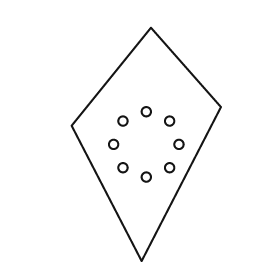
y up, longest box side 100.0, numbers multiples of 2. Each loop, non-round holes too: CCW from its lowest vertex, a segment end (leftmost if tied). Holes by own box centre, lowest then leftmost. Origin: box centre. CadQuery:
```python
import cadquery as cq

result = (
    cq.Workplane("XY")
    .moveTo(-2.0, -50.0)
    .lineTo(32.0, 16.0)
    .lineTo(2.0, 50.0)
    .lineTo(-32.0, 8.0)
    .close()
    .moveTo(0.0, -14.0)
    .circle(2.0)
    .moveTo(-10.0, -10.0)
    .circle(2.0)
    .moveTo(10.0, -10.0)
    .circle(2.0)
    .moveTo(-14.0, 0.0)
    .circle(2.0)
    .moveTo(14.0, 0.0)
    .circle(2.0)
    .moveTo(-10.0, 10.0)
    .circle(2.0)
    .moveTo(10.0, 10.0)
    .circle(2.0)
    .moveTo(0.0, 14.0)
    .circle(2.0)
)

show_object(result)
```